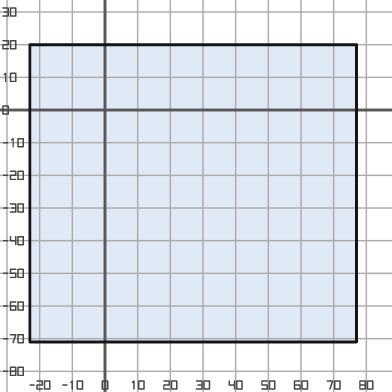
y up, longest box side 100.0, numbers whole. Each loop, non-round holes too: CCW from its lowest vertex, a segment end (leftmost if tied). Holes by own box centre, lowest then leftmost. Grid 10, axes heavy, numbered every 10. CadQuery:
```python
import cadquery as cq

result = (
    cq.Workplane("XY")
    .moveTo(-23.0, -71.0)
    .lineTo(77.0, -71.0)
    .lineTo(77.0, 20.0)
    .lineTo(-23.0, 20.0)
    .close()
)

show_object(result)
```